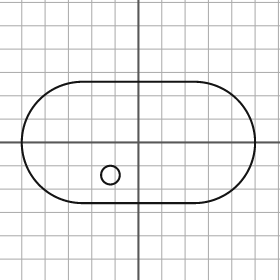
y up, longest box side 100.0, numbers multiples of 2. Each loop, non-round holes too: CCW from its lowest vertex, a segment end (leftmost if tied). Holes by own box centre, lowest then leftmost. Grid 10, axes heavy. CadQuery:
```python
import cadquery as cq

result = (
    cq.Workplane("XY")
    .moveTo(-24.0, -26.0)
    .lineTo(24.0, -26.0)
    .threePointArc((50.0, 0.0), (24.0, 26.0))
    .lineTo(-24.0, 26.0)
    .threePointArc((-50.0, 0.0), (-24.0, -26.0))
    .close()
    .moveTo(-12.0, -14.0)
    .circle(4.0)
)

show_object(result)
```